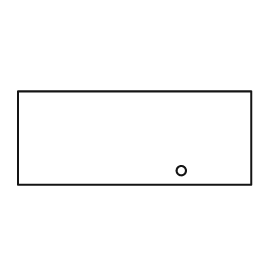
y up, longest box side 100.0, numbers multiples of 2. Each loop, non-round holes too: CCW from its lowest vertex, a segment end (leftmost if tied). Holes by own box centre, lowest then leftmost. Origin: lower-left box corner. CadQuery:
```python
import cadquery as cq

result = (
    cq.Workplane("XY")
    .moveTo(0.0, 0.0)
    .lineTo(100.0, 0.0)
    .lineTo(100.0, 40.0)
    .lineTo(0.0, 40.0)
    .close()
    .moveTo(70.0, 6.0)
    .circle(2.0)
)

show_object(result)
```